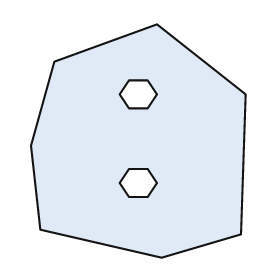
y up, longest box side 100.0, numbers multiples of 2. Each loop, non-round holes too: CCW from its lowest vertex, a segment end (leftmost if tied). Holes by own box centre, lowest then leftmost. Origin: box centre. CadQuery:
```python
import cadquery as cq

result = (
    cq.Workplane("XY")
    .moveTo(10.0, -50.0)
    .lineTo(44.0, -40.0)
    .lineTo(46.0, 20.0)
    .lineTo(8.0, 50.0)
    .lineTo(-36.0, 34.0)
    .lineTo(-46.0, -2.0)
    .lineTo(-42.0, -38.0)
    .close()
    .moveTo(-4.0, -24.0)
    .lineTo(4.0, -24.0)
    .lineTo(8.0, -18.0)
    .lineTo(4.0, -12.0)
    .lineTo(-4.0, -12.0)
    .lineTo(-8.0, -18.0)
    .close()
    .moveTo(-4.0, 14.0)
    .lineTo(4.0, 14.0)
    .lineTo(8.0, 20.0)
    .lineTo(4.0, 26.0)
    .lineTo(-4.0, 26.0)
    .lineTo(-8.0, 20.0)
    .close()
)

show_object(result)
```